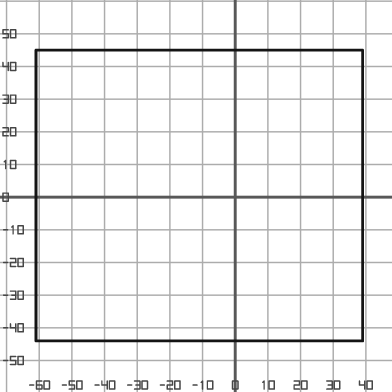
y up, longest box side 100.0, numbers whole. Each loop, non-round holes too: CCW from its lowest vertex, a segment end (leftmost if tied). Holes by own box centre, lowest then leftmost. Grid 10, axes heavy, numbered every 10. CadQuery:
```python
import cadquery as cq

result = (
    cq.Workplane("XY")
    .moveTo(-61.0, -44.0)
    .lineTo(39.0, -44.0)
    .lineTo(39.0, 45.0)
    .lineTo(-61.0, 45.0)
    .close()
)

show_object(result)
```